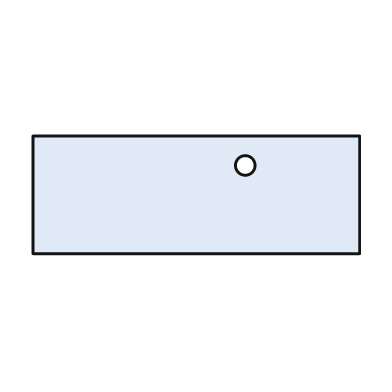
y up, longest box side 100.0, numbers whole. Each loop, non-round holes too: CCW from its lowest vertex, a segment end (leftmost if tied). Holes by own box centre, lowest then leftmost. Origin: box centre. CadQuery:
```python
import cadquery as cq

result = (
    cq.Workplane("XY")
    .moveTo(-50.0, -18.0)
    .lineTo(50.0, -18.0)
    .lineTo(50.0, 18.0)
    .lineTo(-50.0, 18.0)
    .close()
    .moveTo(15.0, 9.0)
    .circle(3.0)
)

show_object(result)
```